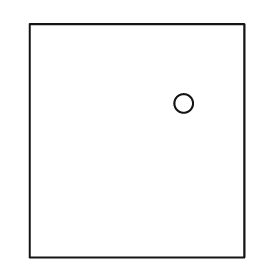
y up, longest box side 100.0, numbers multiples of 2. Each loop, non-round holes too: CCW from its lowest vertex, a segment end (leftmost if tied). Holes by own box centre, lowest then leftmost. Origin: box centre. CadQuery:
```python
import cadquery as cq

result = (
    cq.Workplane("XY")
    .moveTo(-46.0, -50.0)
    .lineTo(46.0, -50.0)
    .lineTo(46.0, 50.0)
    .lineTo(-46.0, 50.0)
    .close()
    .moveTo(20.0, 16.0)
    .circle(4.0)
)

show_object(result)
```